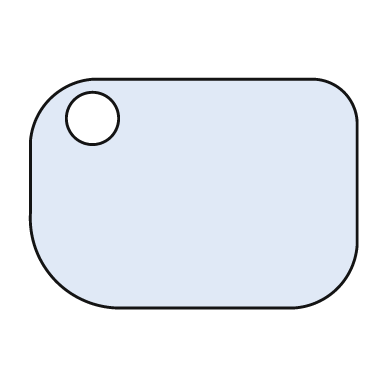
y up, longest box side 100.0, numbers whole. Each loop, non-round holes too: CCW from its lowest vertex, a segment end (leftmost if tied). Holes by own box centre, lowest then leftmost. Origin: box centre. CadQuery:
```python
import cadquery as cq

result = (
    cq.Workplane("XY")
    .moveTo(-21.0, -35.0)
    .lineTo(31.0, -35.0)
    .threePointArc((44.0, -29.0), (50.0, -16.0))
    .lineTo(50.0, 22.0)
    .threePointArc((46.0, 31.0), (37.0, 35.0))
    .lineTo(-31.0, 35.0)
    .threePointArc((-44.0, 29.0), (-50.0, 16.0))
    .lineTo(-50.0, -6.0)
    .threePointArc((-42.0, -27.0), (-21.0, -35.0))
    .close()
    .moveTo(-31.0, 23.0)
    .circle(8.0)
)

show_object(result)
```